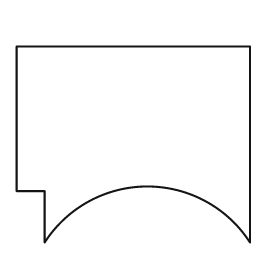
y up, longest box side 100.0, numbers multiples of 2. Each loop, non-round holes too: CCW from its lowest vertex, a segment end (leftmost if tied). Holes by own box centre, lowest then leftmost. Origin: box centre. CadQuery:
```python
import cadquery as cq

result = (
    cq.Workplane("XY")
    .moveTo(-38.0, -42.0)
    .threePointArc((6.0, -18.0), (50.0, -42.0))
    .lineTo(50.0, 42.0)
    .lineTo(-50.0, 42.0)
    .lineTo(-50.0, -20.0)
    .lineTo(-38.0, -20.0)
    .close()
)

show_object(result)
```